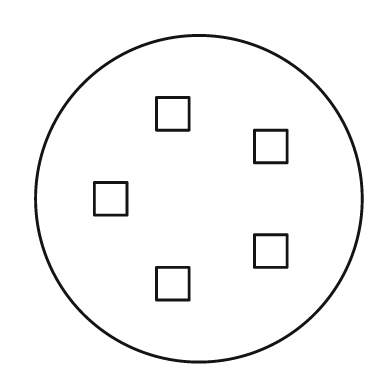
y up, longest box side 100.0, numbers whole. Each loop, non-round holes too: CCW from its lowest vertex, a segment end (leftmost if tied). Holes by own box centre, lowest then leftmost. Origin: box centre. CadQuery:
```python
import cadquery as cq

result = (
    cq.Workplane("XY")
    .moveTo(0.0, 0.0)
    .circle(50.0)
    .moveTo(-13.0, -31.0)
    .lineTo(-3.0, -31.0)
    .lineTo(-3.0, -21.0)
    .lineTo(-13.0, -21.0)
    .close()
    .moveTo(17.0, -21.0)
    .lineTo(27.0, -21.0)
    .lineTo(27.0, -11.0)
    .lineTo(17.0, -11.0)
    .close()
    .moveTo(-32.0, -5.0)
    .lineTo(-22.0, -5.0)
    .lineTo(-22.0, 5.0)
    .lineTo(-32.0, 5.0)
    .close()
    .moveTo(17.0, 11.0)
    .lineTo(27.0, 11.0)
    .lineTo(27.0, 21.0)
    .lineTo(17.0, 21.0)
    .close()
    .moveTo(-13.0, 21.0)
    .lineTo(-3.0, 21.0)
    .lineTo(-3.0, 31.0)
    .lineTo(-13.0, 31.0)
    .close()
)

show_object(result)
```